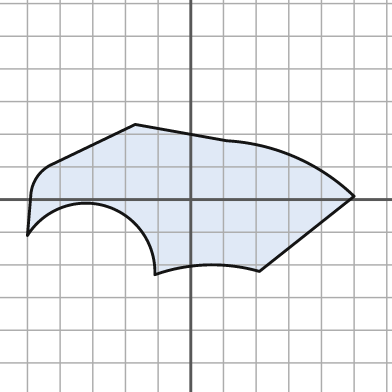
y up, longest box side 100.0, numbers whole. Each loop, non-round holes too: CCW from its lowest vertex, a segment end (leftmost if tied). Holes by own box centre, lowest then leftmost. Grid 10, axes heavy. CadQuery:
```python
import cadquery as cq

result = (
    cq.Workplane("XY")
    .moveTo(-11.0, -23.0)
    .threePointArc((5.0, -20.0), (21.0, -22.0))
    .lineTo(50.0, 1.0)
    .threePointArc((32.0, 13.0), (11.0, 18.0))
    .lineTo(-17.0, 23.0)
    .lineTo(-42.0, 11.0)
    .threePointArc((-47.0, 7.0), (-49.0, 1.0))
    .lineTo(-50.0, -11.0)
    .threePointArc((-26.0, -2.0), (-11.0, -23.0))
    .close()
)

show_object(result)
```